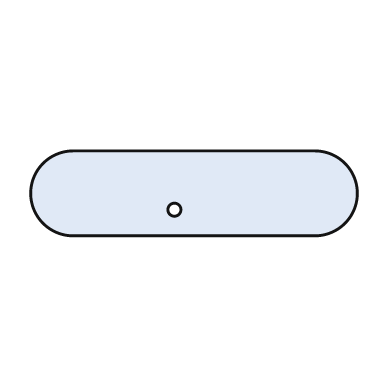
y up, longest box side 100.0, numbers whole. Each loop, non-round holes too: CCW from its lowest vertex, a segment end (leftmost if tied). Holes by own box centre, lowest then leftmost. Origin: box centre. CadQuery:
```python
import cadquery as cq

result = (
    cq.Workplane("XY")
    .moveTo(-37.0, -13.0)
    .lineTo(37.0, -13.0)
    .threePointArc((50.0, 0.0), (37.0, 13.0))
    .lineTo(-37.0, 13.0)
    .threePointArc((-50.0, 0.0), (-37.0, -13.0))
    .close()
    .moveTo(-6.0, -5.0)
    .circle(2.0)
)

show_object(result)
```